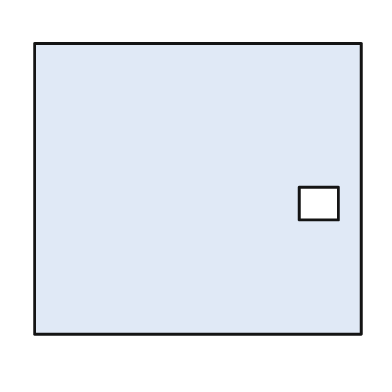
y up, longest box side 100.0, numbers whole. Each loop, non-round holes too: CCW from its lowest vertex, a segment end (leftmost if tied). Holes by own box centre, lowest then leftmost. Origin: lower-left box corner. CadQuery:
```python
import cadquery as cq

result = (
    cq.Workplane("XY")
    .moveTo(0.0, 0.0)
    .lineTo(100.0, 0.0)
    .lineTo(100.0, 89.0)
    .lineTo(0.0, 89.0)
    .close()
    .moveTo(81.0, 35.0)
    .lineTo(93.0, 35.0)
    .lineTo(93.0, 45.0)
    .lineTo(81.0, 45.0)
    .close()
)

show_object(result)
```